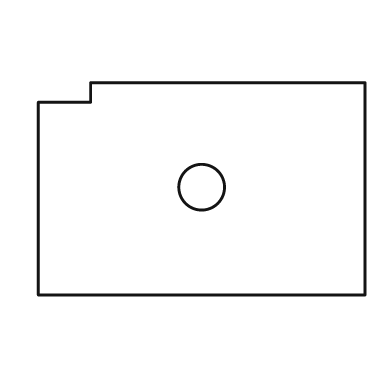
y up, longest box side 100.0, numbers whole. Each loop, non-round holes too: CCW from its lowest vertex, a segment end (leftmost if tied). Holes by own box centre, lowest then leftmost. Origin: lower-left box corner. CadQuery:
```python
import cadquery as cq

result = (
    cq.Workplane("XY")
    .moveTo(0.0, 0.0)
    .lineTo(100.0, 0.0)
    .lineTo(100.0, 65.0)
    .lineTo(16.0, 65.0)
    .lineTo(16.0, 59.0)
    .lineTo(0.0, 59.0)
    .close()
    .moveTo(50.0, 33.0)
    .circle(7.0)
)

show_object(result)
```